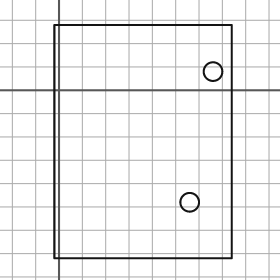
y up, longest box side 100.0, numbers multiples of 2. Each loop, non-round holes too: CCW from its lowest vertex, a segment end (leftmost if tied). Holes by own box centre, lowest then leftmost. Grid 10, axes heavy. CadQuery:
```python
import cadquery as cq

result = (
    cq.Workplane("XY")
    .moveTo(-2.0, -72.0)
    .lineTo(74.0, -72.0)
    .lineTo(74.0, 28.0)
    .lineTo(-2.0, 28.0)
    .close()
    .moveTo(56.0, -48.0)
    .circle(4.0)
    .moveTo(66.0, 8.0)
    .circle(4.0)
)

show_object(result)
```